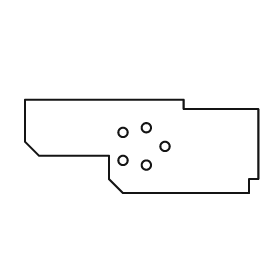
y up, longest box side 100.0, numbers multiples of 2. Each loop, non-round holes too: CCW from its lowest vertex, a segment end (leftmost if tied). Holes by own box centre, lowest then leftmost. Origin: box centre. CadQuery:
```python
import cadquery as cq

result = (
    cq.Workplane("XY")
    .moveTo(-8.0, -20.0)
    .lineTo(46.0, -20.0)
    .lineTo(46.0, -14.0)
    .lineTo(50.0, -14.0)
    .lineTo(50.0, 16.0)
    .lineTo(18.0, 16.0)
    .lineTo(18.0, 20.0)
    .lineTo(-50.0, 20.0)
    .lineTo(-50.0, 2.0)
    .lineTo(-44.0, -4.0)
    .lineTo(-14.0, -4.0)
    .lineTo(-14.0, -14.0)
    .close()
    .moveTo(2.0, -8.0)
    .circle(2.0)
    .moveTo(-8.0, -6.0)
    .circle(2.0)
    .moveTo(10.0, 0.0)
    .circle(2.0)
    .moveTo(-8.0, 6.0)
    .circle(2.0)
    .moveTo(2.0, 8.0)
    .circle(2.0)
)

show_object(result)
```